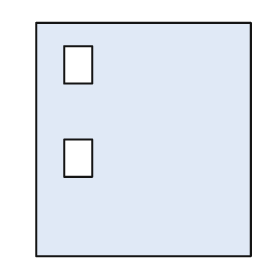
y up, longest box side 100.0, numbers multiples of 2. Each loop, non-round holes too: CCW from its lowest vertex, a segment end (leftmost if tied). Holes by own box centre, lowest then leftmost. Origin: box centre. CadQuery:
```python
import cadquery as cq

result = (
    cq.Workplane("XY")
    .moveTo(-46.0, -50.0)
    .lineTo(46.0, -50.0)
    .lineTo(46.0, 50.0)
    .lineTo(-46.0, 50.0)
    .close()
    .moveTo(-34.0, -16.0)
    .lineTo(-22.0, -16.0)
    .lineTo(-22.0, 0.0)
    .lineTo(-34.0, 0.0)
    .close()
    .moveTo(-34.0, 24.0)
    .lineTo(-22.0, 24.0)
    .lineTo(-22.0, 40.0)
    .lineTo(-34.0, 40.0)
    .close()
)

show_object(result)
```